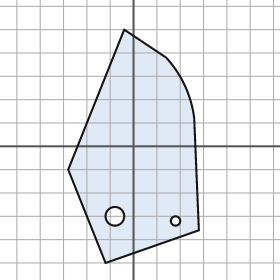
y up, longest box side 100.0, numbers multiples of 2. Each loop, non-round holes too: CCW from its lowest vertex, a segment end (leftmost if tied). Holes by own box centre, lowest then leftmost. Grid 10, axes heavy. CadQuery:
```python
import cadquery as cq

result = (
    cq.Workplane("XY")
    .moveTo(-12.0, -50.0)
    .lineTo(28.0, -36.0)
    .lineTo(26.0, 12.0)
    .threePointArc((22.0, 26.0), (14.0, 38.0))
    .lineTo(-4.0, 50.0)
    .lineTo(-28.0, -10.0)
    .close()
    .moveTo(18.0, -32.0)
    .circle(2.0)
    .moveTo(-8.0, -30.0)
    .circle(4.0)
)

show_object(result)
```